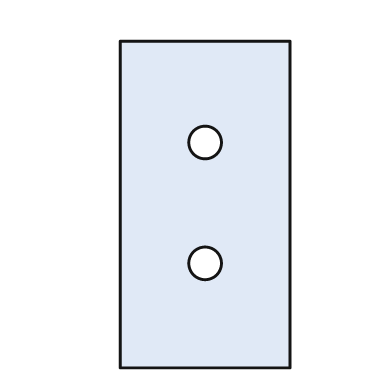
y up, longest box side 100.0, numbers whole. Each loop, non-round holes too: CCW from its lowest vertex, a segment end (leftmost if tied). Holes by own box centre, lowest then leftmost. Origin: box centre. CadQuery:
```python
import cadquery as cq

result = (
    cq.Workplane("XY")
    .moveTo(-26.0, -50.0)
    .lineTo(26.0, -50.0)
    .lineTo(26.0, 50.0)
    .lineTo(-26.0, 50.0)
    .close()
    .moveTo(0.0, -18.0)
    .circle(5.0)
    .moveTo(0.0, 19.0)
    .circle(5.0)
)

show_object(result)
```